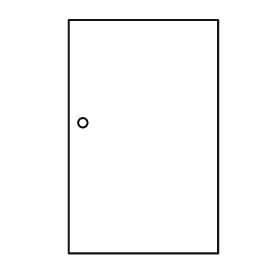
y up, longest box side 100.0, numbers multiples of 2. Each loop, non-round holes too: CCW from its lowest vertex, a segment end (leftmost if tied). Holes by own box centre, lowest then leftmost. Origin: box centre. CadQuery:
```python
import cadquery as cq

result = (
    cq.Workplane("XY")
    .moveTo(-32.0, -50.0)
    .lineTo(32.0, -50.0)
    .lineTo(32.0, 50.0)
    .lineTo(-32.0, 50.0)
    .close()
    .moveTo(-26.0, 6.0)
    .circle(2.0)
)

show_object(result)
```